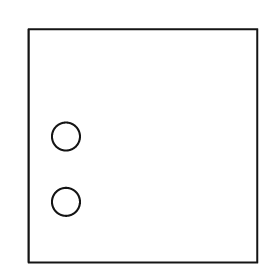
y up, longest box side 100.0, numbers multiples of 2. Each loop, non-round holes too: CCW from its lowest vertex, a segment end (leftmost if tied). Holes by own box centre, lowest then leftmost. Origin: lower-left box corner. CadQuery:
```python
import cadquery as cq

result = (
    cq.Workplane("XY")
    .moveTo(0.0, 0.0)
    .lineTo(98.0, 0.0)
    .lineTo(98.0, 100.0)
    .lineTo(0.0, 100.0)
    .close()
    .moveTo(16.0, 26.0)
    .circle(6.0)
    .moveTo(16.0, 54.0)
    .circle(6.0)
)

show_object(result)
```